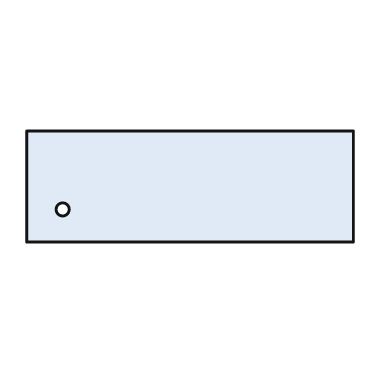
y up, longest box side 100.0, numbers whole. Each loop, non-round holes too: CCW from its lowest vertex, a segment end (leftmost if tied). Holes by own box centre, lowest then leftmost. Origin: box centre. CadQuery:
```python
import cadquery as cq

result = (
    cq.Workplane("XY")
    .moveTo(-50.0, -17.0)
    .lineTo(50.0, -17.0)
    .lineTo(50.0, 17.0)
    .lineTo(-50.0, 17.0)
    .close()
    .moveTo(-39.0, -7.0)
    .circle(2.0)
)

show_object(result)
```